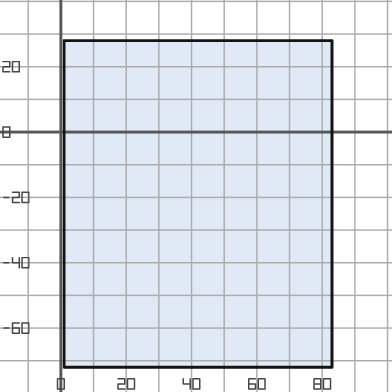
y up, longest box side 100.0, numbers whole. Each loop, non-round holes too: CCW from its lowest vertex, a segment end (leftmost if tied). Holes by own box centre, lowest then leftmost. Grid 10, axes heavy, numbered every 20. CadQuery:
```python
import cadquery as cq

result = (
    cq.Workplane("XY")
    .moveTo(1.0, -72.0)
    .lineTo(83.0, -72.0)
    .lineTo(83.0, 28.0)
    .lineTo(1.0, 28.0)
    .close()
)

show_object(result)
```